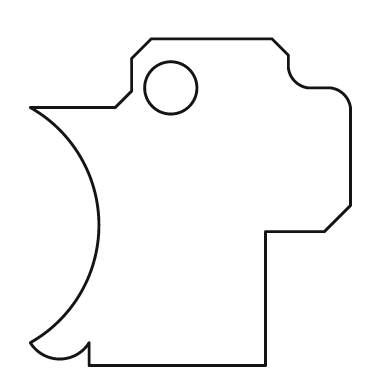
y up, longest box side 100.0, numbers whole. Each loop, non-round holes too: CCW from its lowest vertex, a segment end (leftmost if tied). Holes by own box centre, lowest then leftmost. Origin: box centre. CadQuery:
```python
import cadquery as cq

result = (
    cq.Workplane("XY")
    .moveTo(-31.0, -50.0)
    .lineTo(23.0, -50.0)
    .lineTo(23.0, -9.0)
    .lineTo(41.0, -9.0)
    .lineTo(49.0, -1.0)
    .lineTo(49.0, 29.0)
    .threePointArc((47.0, 33.0), (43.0, 35.0))
    .lineTo(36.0, 35.0)
    .threePointArc((32.0, 37.0), (30.0, 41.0))
    .lineTo(30.0, 45.0)
    .lineTo(25.0, 50.0)
    .lineTo(-12.0, 50.0)
    .lineTo(-18.0, 44.0)
    .lineTo(-18.0, 34.0)
    .lineTo(-23.0, 29.0)
    .lineTo(-49.0, 29.0)
    .threePointArc((-28.0, -7.0), (-49.0, -43.0))
    .threePointArc((-40.0, -48.0), (-31.0, -43.0))
    .close()
    .moveTo(-6.0, 35.0)
    .circle(8.0)
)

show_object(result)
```